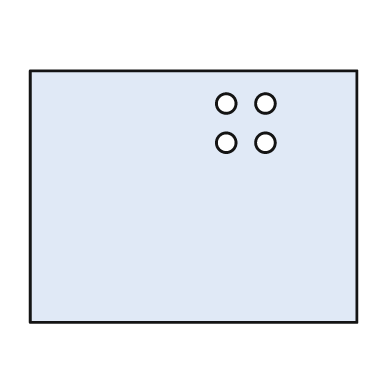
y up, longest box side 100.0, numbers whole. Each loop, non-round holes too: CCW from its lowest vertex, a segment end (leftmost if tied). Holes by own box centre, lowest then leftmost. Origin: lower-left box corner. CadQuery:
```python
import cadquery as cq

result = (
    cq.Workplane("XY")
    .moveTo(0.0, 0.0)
    .lineTo(100.0, 0.0)
    .lineTo(100.0, 77.0)
    .lineTo(0.0, 77.0)
    .close()
    .moveTo(60.0, 55.0)
    .circle(3.0)
    .moveTo(72.0, 55.0)
    .circle(3.0)
    .moveTo(60.0, 67.0)
    .circle(3.0)
    .moveTo(72.0, 67.0)
    .circle(3.0)
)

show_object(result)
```